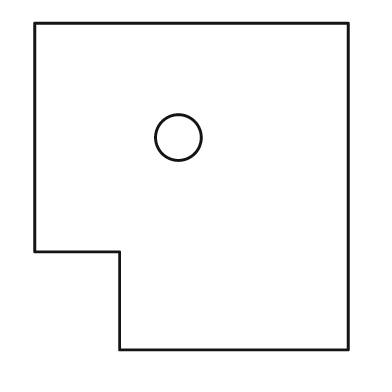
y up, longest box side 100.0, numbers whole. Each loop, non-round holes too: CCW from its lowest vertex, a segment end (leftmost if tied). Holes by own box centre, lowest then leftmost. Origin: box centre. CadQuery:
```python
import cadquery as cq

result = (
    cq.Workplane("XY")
    .moveTo(-22.0, -50.0)
    .lineTo(48.0, -50.0)
    .lineTo(48.0, 50.0)
    .lineTo(-48.0, 50.0)
    .lineTo(-48.0, -20.0)
    .lineTo(-22.0, -20.0)
    .close()
    .moveTo(-4.0, 15.0)
    .circle(7.0)
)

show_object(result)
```